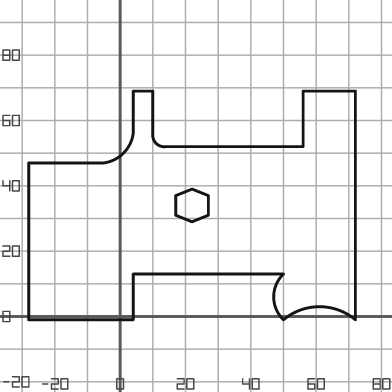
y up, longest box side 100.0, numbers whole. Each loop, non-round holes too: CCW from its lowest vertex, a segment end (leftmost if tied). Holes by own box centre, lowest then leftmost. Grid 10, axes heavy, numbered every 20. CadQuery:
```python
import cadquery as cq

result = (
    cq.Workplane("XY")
    .moveTo(-28.0, -1.0)
    .lineTo(4.0, -1.0)
    .lineTo(4.0, 13.0)
    .lineTo(50.0, 13.0)
    .threePointArc((47.0, 6.0), (50.0, -1.0))
    .threePointArc((61.0, 3.0), (72.0, -1.0))
    .lineTo(72.0, 69.0)
    .lineTo(56.0, 69.0)
    .lineTo(56.0, 52.0)
    .lineTo(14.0, 52.0)
    .threePointArc((11.0, 53.0), (10.0, 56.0))
    .lineTo(10.0, 69.0)
    .lineTo(4.0, 69.0)
    .lineTo(4.0, 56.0)
    .threePointArc((1.0, 50.0), (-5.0, 47.0))
    .lineTo(-28.0, 47.0)
    .close()
    .moveTo(22.0, 29.0)
    .lineTo(27.0, 31.0)
    .lineTo(27.0, 37.0)
    .lineTo(22.0, 39.0)
    .lineTo(17.0, 37.0)
    .lineTo(17.0, 31.0)
    .close()
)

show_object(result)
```